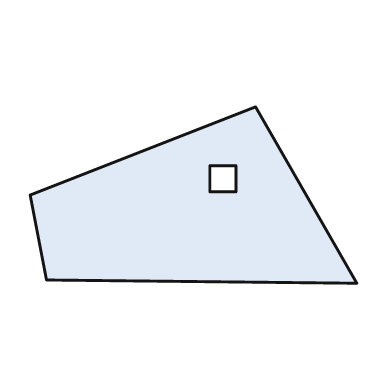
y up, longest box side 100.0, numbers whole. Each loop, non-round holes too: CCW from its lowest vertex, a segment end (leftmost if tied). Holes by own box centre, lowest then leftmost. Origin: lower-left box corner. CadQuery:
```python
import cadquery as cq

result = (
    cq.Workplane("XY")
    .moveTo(100.0, 0.0)
    .lineTo(69.0, 54.0)
    .lineTo(0.0, 27.0)
    .lineTo(5.0, 1.0)
    .close()
    .moveTo(55.0, 28.0)
    .lineTo(63.0, 28.0)
    .lineTo(63.0, 36.0)
    .lineTo(55.0, 36.0)
    .close()
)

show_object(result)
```